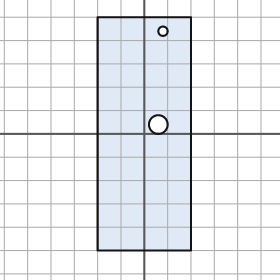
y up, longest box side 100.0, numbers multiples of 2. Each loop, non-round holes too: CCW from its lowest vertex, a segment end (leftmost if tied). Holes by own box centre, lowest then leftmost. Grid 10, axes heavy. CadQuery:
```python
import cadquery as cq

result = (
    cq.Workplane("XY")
    .moveTo(-20.0, -50.0)
    .lineTo(20.0, -50.0)
    .lineTo(20.0, 50.0)
    .lineTo(-20.0, 50.0)
    .close()
    .moveTo(6.0, 4.0)
    .circle(4.0)
    .moveTo(8.0, 44.0)
    .circle(2.0)
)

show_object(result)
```